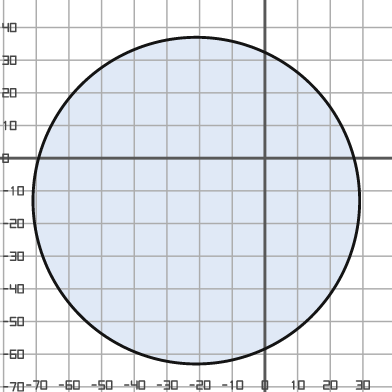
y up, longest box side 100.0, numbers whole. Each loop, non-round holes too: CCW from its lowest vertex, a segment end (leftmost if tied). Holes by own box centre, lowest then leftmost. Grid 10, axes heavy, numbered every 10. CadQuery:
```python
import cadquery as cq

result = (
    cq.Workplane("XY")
    .moveTo(-21.0, -13.0)
    .circle(50.0)
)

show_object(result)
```